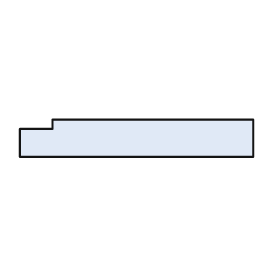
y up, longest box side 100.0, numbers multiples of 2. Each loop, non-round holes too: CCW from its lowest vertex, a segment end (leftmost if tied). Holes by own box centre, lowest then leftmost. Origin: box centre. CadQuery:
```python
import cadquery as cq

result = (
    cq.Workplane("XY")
    .moveTo(-50.0, -8.0)
    .lineTo(50.0, -8.0)
    .lineTo(50.0, 8.0)
    .lineTo(-36.0, 8.0)
    .lineTo(-36.0, 4.0)
    .lineTo(-50.0, 4.0)
    .close()
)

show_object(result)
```